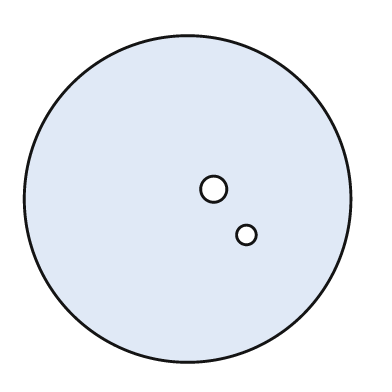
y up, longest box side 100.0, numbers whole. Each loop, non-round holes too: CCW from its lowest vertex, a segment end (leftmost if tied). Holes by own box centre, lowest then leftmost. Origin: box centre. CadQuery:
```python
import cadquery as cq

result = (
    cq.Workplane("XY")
    .moveTo(0.0, 0.0)
    .circle(50.0)
    .moveTo(18.0, -11.0)
    .circle(3.0)
    .moveTo(8.0, 3.0)
    .circle(4.0)
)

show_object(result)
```